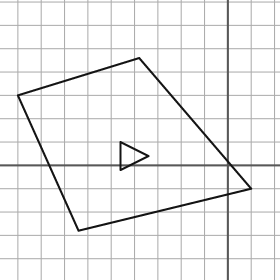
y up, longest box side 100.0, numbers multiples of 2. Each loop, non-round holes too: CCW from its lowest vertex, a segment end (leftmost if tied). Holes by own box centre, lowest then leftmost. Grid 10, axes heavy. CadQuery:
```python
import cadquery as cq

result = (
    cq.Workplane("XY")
    .moveTo(-64.0, -28.0)
    .lineTo(10.0, -10.0)
    .lineTo(-38.0, 46.0)
    .lineTo(-90.0, 30.0)
    .close()
    .moveTo(-46.0, -2.0)
    .lineTo(-34.0, 4.0)
    .lineTo(-46.0, 10.0)
    .close()
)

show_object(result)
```